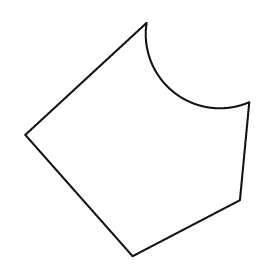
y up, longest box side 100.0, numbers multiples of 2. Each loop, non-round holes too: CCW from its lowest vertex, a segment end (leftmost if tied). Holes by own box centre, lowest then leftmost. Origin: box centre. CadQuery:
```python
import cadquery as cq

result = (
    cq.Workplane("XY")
    .moveTo(-2.0, -50.0)
    .lineTo(44.0, -26.0)
    .lineTo(48.0, 16.0)
    .threePointArc((16.0, 20.0), (4.0, 50.0))
    .lineTo(-48.0, 2.0)
    .close()
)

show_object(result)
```